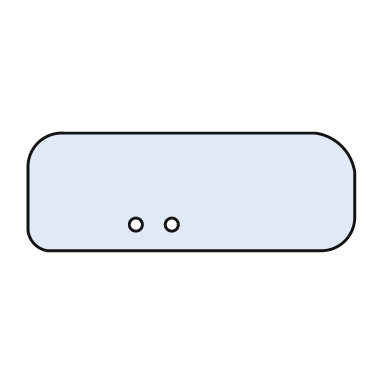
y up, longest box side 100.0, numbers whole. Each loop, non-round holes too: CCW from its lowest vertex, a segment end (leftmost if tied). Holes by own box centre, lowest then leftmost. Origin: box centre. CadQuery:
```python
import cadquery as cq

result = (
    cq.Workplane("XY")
    .moveTo(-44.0, -18.0)
    .lineTo(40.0, -18.0)
    .threePointArc((47.0, -15.0), (50.0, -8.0))
    .lineTo(50.0, 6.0)
    .threePointArc((46.0, 14.0), (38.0, 18.0))
    .lineTo(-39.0, 18.0)
    .threePointArc((-47.0, 15.0), (-50.0, 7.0))
    .lineTo(-50.0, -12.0)
    .threePointArc((-48.0, -16.0), (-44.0, -18.0))
    .close()
    .moveTo(-17.0, -10.0)
    .circle(2.0)
    .moveTo(-6.0, -10.0)
    .circle(2.0)
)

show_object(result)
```